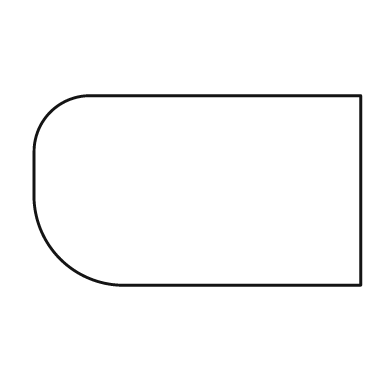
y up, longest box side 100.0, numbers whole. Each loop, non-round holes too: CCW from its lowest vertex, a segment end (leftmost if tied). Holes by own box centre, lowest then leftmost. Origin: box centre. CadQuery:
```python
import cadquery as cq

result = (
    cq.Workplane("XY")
    .moveTo(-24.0, -29.0)
    .lineTo(50.0, -29.0)
    .lineTo(50.0, 29.0)
    .lineTo(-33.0, 29.0)
    .threePointArc((-45.0, 24.0), (-50.0, 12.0))
    .lineTo(-50.0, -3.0)
    .threePointArc((-42.0, -21.0), (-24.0, -29.0))
    .close()
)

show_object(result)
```